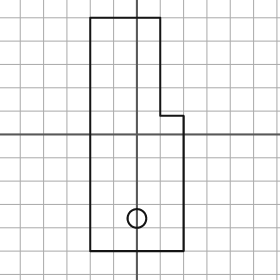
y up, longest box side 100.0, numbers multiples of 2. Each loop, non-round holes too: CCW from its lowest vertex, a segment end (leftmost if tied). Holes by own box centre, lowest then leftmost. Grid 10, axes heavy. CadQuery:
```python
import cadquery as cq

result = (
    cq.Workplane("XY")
    .moveTo(-20.0, -50.0)
    .lineTo(20.0, -50.0)
    .lineTo(20.0, 8.0)
    .lineTo(10.0, 8.0)
    .lineTo(10.0, 50.0)
    .lineTo(-20.0, 50.0)
    .close()
    .moveTo(0.0, -36.0)
    .circle(4.0)
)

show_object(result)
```